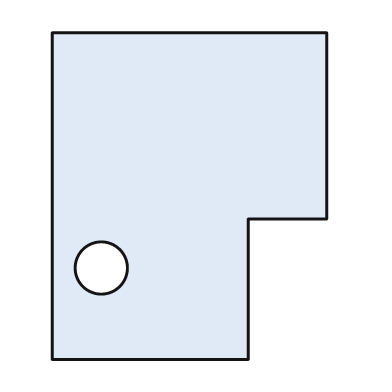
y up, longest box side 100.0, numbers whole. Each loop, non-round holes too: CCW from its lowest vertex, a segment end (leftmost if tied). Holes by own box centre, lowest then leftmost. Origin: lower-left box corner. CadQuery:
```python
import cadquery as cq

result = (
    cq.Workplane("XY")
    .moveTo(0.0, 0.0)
    .lineTo(60.0, 0.0)
    .lineTo(60.0, 43.0)
    .lineTo(84.0, 43.0)
    .lineTo(84.0, 100.0)
    .lineTo(0.0, 100.0)
    .close()
    .moveTo(15.0, 28.0)
    .circle(8.0)
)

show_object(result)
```